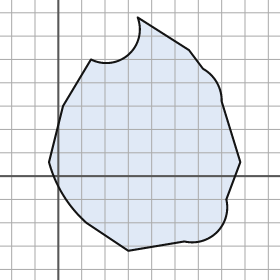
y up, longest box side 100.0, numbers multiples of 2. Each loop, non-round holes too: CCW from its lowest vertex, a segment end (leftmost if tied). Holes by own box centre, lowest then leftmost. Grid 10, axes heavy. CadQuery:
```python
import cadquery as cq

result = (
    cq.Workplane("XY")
    .moveTo(30.0, -32.0)
    .lineTo(54.0, -28.0)
    .threePointArc((68.0, -24.0), (72.0, -10.0))
    .lineTo(78.0, 6.0)
    .lineTo(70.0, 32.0)
    .threePointArc((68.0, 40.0), (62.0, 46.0))
    .lineTo(56.0, 54.0)
    .lineTo(34.0, 68.0)
    .threePointArc((30.0, 52.0), (14.0, 50.0))
    .lineTo(2.0, 30.0)
    .lineTo(-4.0, 6.0)
    .threePointArc((2.0, -8.0), (12.0, -20.0))
    .close()
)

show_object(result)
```